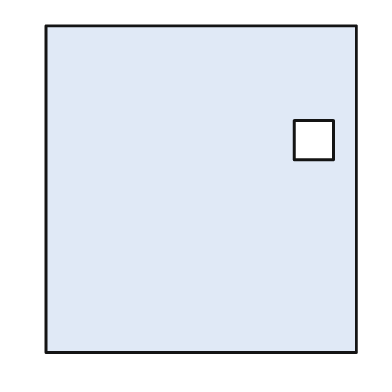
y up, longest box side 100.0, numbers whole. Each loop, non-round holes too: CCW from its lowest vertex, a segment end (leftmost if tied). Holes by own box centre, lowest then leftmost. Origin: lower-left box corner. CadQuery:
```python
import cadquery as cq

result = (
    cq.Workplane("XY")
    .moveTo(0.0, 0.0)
    .lineTo(95.0, 0.0)
    .lineTo(95.0, 100.0)
    .lineTo(0.0, 100.0)
    .close()
    .moveTo(76.0, 59.0)
    .lineTo(88.0, 59.0)
    .lineTo(88.0, 71.0)
    .lineTo(76.0, 71.0)
    .close()
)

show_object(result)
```